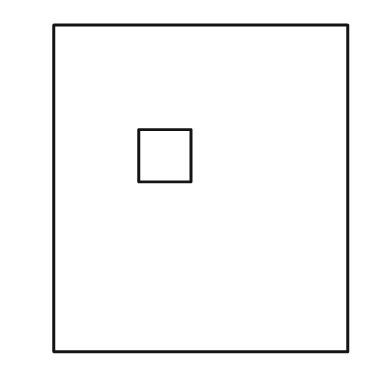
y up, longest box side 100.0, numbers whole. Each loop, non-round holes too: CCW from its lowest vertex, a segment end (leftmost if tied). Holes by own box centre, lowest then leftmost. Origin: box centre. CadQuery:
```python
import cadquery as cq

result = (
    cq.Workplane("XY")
    .moveTo(-45.0, -50.0)
    .lineTo(45.0, -50.0)
    .lineTo(45.0, 50.0)
    .lineTo(-45.0, 50.0)
    .close()
    .moveTo(-19.0, 2.0)
    .lineTo(-3.0, 2.0)
    .lineTo(-3.0, 18.0)
    .lineTo(-19.0, 18.0)
    .close()
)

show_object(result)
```